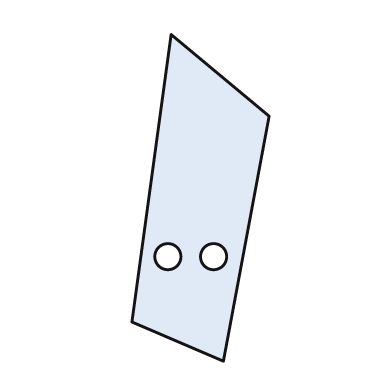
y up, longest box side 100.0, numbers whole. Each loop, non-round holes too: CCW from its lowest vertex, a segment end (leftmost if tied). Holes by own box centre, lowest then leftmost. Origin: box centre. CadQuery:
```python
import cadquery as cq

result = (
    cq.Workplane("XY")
    .moveTo(7.0, -50.0)
    .lineTo(21.0, 25.0)
    .lineTo(-9.0, 50.0)
    .lineTo(-21.0, -38.0)
    .close()
    .moveTo(-10.0, -18.0)
    .circle(4.0)
    .moveTo(4.0, -18.0)
    .circle(4.0)
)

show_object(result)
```